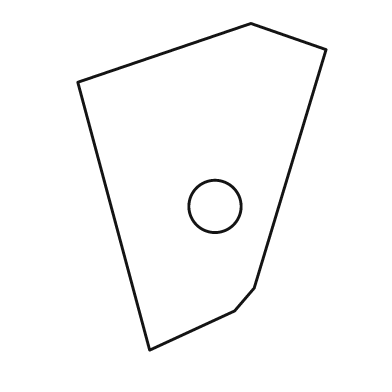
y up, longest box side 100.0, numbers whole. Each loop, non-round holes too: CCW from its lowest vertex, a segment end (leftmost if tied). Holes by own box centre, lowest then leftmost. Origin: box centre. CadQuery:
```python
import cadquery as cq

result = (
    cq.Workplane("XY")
    .moveTo(-16.0, -50.0)
    .lineTo(10.0, -38.0)
    .lineTo(16.0, -31.0)
    .lineTo(38.0, 42.0)
    .lineTo(15.0, 50.0)
    .lineTo(-38.0, 32.0)
    .close()
    .moveTo(4.0, -6.0)
    .circle(8.0)
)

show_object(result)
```